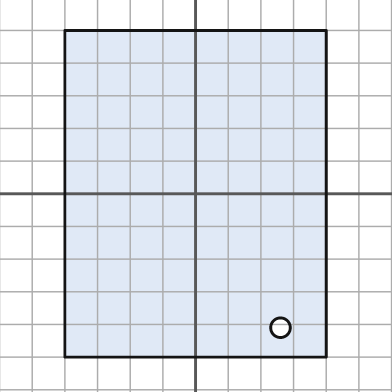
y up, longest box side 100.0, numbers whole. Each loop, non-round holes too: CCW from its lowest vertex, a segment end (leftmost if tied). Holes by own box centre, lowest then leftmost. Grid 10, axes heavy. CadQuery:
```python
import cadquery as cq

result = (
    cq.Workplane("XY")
    .moveTo(-40.0, -50.0)
    .lineTo(40.0, -50.0)
    .lineTo(40.0, 50.0)
    .lineTo(-40.0, 50.0)
    .close()
    .moveTo(26.0, -41.0)
    .circle(3.0)
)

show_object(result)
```